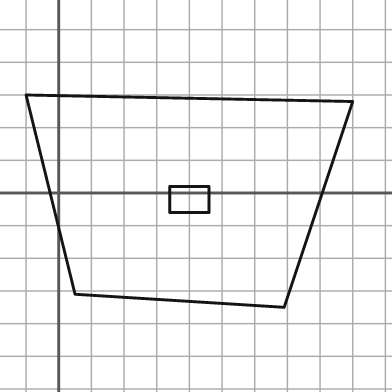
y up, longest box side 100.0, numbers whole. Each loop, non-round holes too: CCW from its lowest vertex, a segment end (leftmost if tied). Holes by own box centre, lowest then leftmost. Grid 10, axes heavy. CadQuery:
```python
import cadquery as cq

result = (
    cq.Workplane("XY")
    .moveTo(69.0, -35.0)
    .lineTo(90.0, 28.0)
    .lineTo(-10.0, 30.0)
    .lineTo(5.0, -31.0)
    .close()
    .moveTo(34.0, -6.0)
    .lineTo(46.0, -6.0)
    .lineTo(46.0, 2.0)
    .lineTo(34.0, 2.0)
    .close()
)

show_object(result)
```